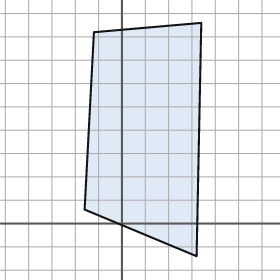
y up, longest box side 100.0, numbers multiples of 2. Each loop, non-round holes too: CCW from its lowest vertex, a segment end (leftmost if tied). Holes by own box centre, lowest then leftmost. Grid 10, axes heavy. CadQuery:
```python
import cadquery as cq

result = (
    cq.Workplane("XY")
    .moveTo(32.0, -14.0)
    .lineTo(34.0, 86.0)
    .lineTo(-12.0, 82.0)
    .lineTo(-16.0, 6.0)
    .close()
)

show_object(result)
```